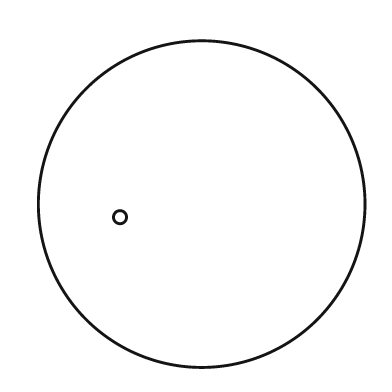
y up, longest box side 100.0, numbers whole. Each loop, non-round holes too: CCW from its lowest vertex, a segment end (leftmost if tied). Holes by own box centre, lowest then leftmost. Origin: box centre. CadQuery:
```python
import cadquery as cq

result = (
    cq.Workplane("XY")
    .moveTo(0.0, 0.0)
    .circle(50.0)
    .moveTo(-25.0, -4.0)
    .circle(2.0)
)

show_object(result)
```